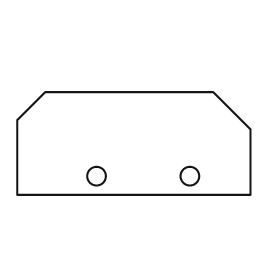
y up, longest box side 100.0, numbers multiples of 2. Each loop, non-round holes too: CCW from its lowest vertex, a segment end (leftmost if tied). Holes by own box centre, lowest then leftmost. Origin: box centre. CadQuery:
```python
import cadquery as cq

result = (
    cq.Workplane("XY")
    .moveTo(-50.0, -22.0)
    .lineTo(50.0, -22.0)
    .lineTo(50.0, 6.0)
    .lineTo(34.0, 22.0)
    .lineTo(-38.0, 22.0)
    .lineTo(-50.0, 10.0)
    .close()
    .moveTo(-16.0, -14.0)
    .circle(4.0)
    .moveTo(24.0, -14.0)
    .circle(4.0)
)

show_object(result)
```